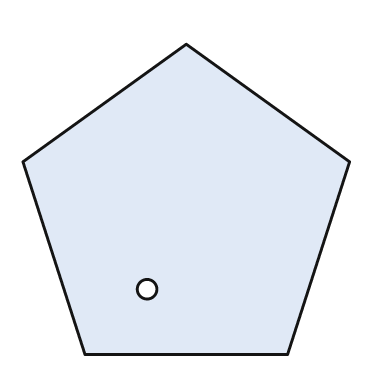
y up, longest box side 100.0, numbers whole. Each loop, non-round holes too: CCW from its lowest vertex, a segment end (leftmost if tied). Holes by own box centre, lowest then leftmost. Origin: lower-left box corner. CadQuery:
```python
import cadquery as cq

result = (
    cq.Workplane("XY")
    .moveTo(19.0, 0.0)
    .lineTo(81.0, 0.0)
    .lineTo(100.0, 59.0)
    .lineTo(50.0, 95.0)
    .lineTo(0.0, 59.0)
    .close()
    .moveTo(38.0, 20.0)
    .circle(3.0)
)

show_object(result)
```